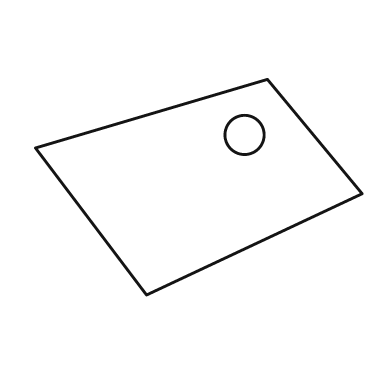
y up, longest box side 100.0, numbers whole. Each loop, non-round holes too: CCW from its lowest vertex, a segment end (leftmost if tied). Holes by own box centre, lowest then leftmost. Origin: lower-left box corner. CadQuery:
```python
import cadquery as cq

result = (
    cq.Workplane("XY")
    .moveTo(34.0, 0.0)
    .lineTo(100.0, 31.0)
    .lineTo(71.0, 66.0)
    .lineTo(0.0, 45.0)
    .close()
    .moveTo(64.0, 49.0)
    .circle(6.0)
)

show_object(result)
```